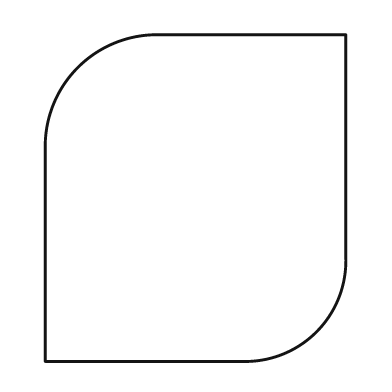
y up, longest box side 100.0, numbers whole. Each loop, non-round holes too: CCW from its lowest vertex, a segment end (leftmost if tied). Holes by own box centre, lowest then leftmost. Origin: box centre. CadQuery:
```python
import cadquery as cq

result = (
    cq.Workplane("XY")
    .moveTo(-46.0, -50.0)
    .lineTo(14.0, -50.0)
    .threePointArc((37.0, -41.0), (46.0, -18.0))
    .lineTo(46.0, 50.0)
    .lineTo(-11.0, 50.0)
    .threePointArc((-36.0, 40.0), (-46.0, 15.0))
    .close()
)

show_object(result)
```